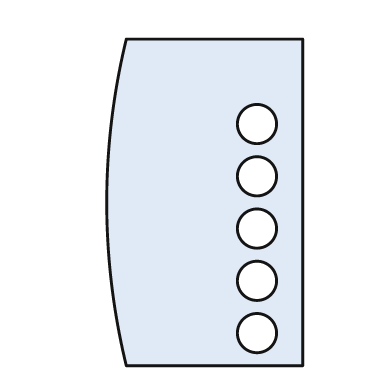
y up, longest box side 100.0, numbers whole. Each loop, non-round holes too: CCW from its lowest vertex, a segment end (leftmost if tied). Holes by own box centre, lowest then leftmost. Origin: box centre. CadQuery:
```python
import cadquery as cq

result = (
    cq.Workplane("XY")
    .moveTo(-24.0, -50.0)
    .lineTo(30.0, -50.0)
    .lineTo(30.0, 50.0)
    .lineTo(-24.0, 50.0)
    .threePointArc((-30.0, 0.0), (-24.0, -50.0))
    .close()
    .moveTo(16.0, -40.0)
    .circle(6.0)
    .moveTo(16.0, -24.0)
    .circle(6.0)
    .moveTo(16.0, -8.0)
    .circle(6.0)
    .moveTo(16.0, 8.0)
    .circle(6.0)
    .moveTo(16.0, 24.0)
    .circle(6.0)
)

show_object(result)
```